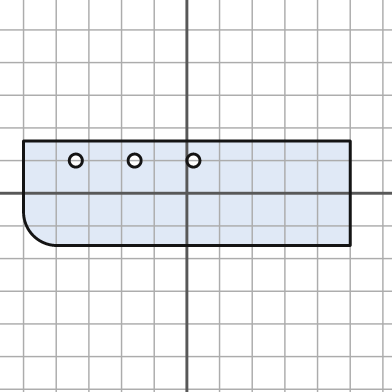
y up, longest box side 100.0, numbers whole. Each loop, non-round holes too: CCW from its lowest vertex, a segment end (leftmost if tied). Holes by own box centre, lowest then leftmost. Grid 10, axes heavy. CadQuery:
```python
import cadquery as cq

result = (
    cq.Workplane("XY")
    .moveTo(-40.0, -16.0)
    .lineTo(50.0, -16.0)
    .lineTo(50.0, 16.0)
    .lineTo(-50.0, 16.0)
    .lineTo(-50.0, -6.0)
    .threePointArc((-47.0, -13.0), (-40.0, -16.0))
    .close()
    .moveTo(-34.0, 10.0)
    .circle(2.0)
    .moveTo(-16.0, 10.0)
    .circle(2.0)
    .moveTo(2.0, 10.0)
    .circle(2.0)
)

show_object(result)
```